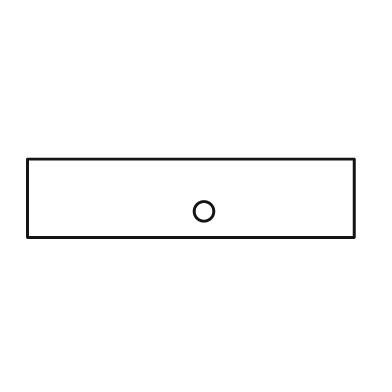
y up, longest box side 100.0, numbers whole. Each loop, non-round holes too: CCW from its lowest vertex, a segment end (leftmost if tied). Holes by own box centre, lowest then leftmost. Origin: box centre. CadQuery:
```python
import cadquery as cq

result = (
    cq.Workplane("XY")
    .moveTo(-50.0, -12.0)
    .lineTo(50.0, -12.0)
    .lineTo(50.0, 12.0)
    .lineTo(-50.0, 12.0)
    .close()
    .moveTo(4.0, -4.0)
    .circle(3.0)
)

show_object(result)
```